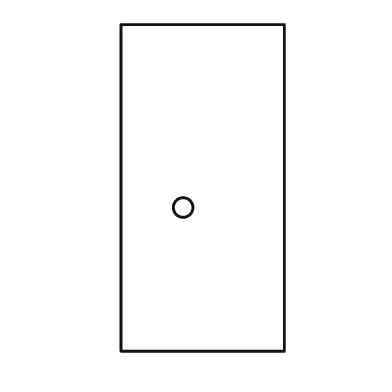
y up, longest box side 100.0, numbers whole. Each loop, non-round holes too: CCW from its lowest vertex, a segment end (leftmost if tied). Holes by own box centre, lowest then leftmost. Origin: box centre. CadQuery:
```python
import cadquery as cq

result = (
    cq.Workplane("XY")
    .moveTo(-25.0, -50.0)
    .lineTo(25.0, -50.0)
    .lineTo(25.0, 50.0)
    .lineTo(-25.0, 50.0)
    .close()
    .moveTo(-6.0, -6.0)
    .circle(3.0)
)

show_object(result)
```